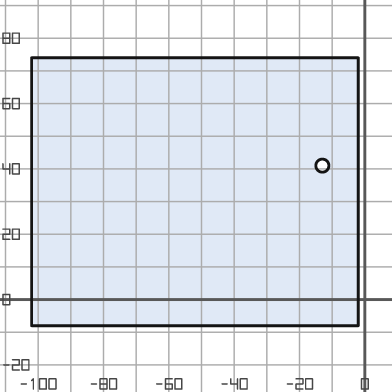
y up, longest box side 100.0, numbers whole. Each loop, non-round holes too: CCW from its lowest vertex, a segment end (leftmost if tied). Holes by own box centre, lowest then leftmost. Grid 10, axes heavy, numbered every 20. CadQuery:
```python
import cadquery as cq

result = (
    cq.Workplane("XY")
    .moveTo(-102.0, -8.0)
    .lineTo(-2.0, -8.0)
    .lineTo(-2.0, 74.0)
    .lineTo(-102.0, 74.0)
    .close()
    .moveTo(-13.0, 41.0)
    .circle(2.0)
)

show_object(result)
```